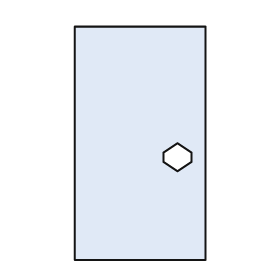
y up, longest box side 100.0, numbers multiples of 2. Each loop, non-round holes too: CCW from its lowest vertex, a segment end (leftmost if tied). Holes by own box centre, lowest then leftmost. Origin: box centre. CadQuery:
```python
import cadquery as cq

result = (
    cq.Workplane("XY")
    .moveTo(-28.0, -50.0)
    .lineTo(28.0, -50.0)
    .lineTo(28.0, 50.0)
    .lineTo(-28.0, 50.0)
    .close()
    .moveTo(16.0, -12.0)
    .lineTo(22.0, -8.0)
    .lineTo(22.0, -4.0)
    .lineTo(16.0, 0.0)
    .lineTo(10.0, -4.0)
    .lineTo(10.0, -8.0)
    .close()
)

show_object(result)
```